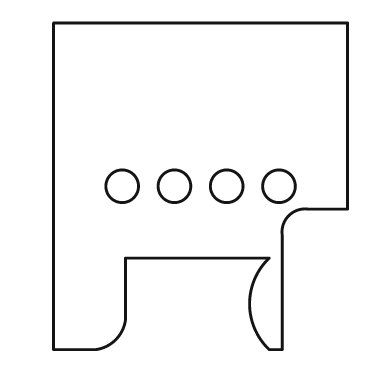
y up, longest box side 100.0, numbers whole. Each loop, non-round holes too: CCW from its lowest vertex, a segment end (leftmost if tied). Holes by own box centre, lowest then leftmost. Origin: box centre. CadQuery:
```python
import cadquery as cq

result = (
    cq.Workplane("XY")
    .moveTo(-45.0, -50.0)
    .lineTo(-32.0, -50.0)
    .threePointArc((-26.0, -47.0), (-23.0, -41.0))
    .lineTo(-23.0, -22.0)
    .lineTo(21.0, -22.0)
    .threePointArc((15.0, -36.0), (21.0, -50.0))
    .lineTo(25.0, -50.0)
    .lineTo(25.0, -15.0)
    .threePointArc((27.0, -9.0), (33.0, -7.0))
    .lineTo(45.0, -7.0)
    .lineTo(45.0, 50.0)
    .lineTo(-45.0, 50.0)
    .close()
    .moveTo(-24.0, 0.0)
    .circle(5.0)
    .moveTo(-8.0, 0.0)
    .circle(5.0)
    .moveTo(8.0, 0.0)
    .circle(5.0)
    .moveTo(24.0, 0.0)
    .circle(5.0)
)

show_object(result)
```